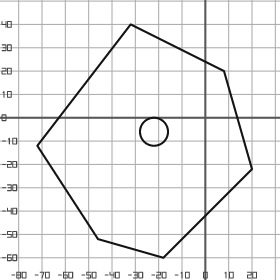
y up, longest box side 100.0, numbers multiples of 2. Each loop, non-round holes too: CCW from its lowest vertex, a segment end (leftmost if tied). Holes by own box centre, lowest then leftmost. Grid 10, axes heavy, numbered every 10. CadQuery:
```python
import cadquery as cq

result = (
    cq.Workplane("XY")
    .moveTo(-18.0, -60.0)
    .lineTo(20.0, -22.0)
    .lineTo(8.0, 20.0)
    .lineTo(-32.0, 40.0)
    .lineTo(-72.0, -12.0)
    .lineTo(-46.0, -52.0)
    .close()
    .moveTo(-22.0, -6.0)
    .circle(6.0)
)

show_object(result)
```